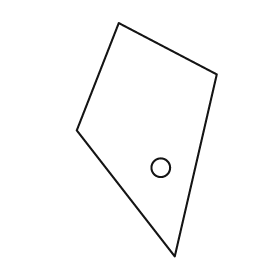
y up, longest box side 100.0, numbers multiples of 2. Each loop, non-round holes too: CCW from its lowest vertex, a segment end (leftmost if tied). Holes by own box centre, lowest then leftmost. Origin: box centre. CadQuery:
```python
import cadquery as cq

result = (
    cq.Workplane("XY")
    .moveTo(12.0, -50.0)
    .lineTo(30.0, 28.0)
    .lineTo(-12.0, 50.0)
    .lineTo(-30.0, 4.0)
    .close()
    .moveTo(6.0, -12.0)
    .circle(4.0)
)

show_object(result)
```